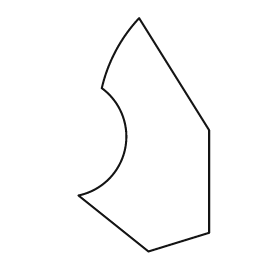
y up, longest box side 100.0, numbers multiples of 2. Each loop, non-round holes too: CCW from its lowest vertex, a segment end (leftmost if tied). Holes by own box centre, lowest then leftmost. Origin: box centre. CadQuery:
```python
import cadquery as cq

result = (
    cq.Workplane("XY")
    .moveTo(2.0, -50.0)
    .lineTo(28.0, -42.0)
    .lineTo(28.0, 2.0)
    .lineTo(-2.0, 50.0)
    .threePointArc((-12.0, 36.0), (-18.0, 20.0))
    .threePointArc((-8.0, -6.0), (-28.0, -26.0))
    .close()
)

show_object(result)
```